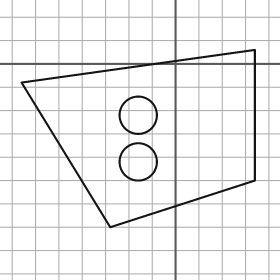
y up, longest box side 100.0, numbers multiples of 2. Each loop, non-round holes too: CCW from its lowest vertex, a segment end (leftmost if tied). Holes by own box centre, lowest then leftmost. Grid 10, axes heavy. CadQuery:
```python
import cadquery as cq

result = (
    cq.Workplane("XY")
    .moveTo(-28.0, -70.0)
    .lineTo(34.0, -50.0)
    .lineTo(34.0, 6.0)
    .lineTo(-66.0, -8.0)
    .close()
    .moveTo(-16.0, -42.0)
    .circle(8.0)
    .moveTo(-16.0, -22.0)
    .circle(8.0)
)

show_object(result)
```